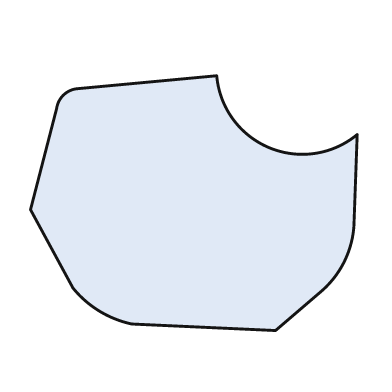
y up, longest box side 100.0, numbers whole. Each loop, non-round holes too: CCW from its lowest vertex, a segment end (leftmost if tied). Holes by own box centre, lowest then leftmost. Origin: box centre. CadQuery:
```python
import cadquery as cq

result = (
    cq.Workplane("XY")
    .moveTo(25.0, -39.0)
    .lineTo(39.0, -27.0)
    .threePointArc((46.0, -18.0), (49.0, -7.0))
    .lineTo(50.0, 21.0)
    .threePointArc((23.0, 17.0), (7.0, 39.0))
    .lineTo(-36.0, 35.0)
    .threePointArc((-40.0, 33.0), (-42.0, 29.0))
    .lineTo(-50.0, -2.0)
    .lineTo(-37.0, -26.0)
    .threePointArc((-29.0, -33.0), (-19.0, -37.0))
    .close()
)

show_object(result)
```